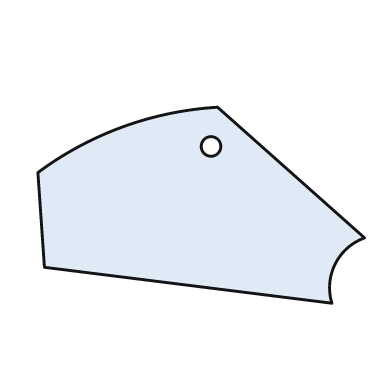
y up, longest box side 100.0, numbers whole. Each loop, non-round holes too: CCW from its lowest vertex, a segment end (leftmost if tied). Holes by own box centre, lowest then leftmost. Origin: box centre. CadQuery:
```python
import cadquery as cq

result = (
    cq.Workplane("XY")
    .moveTo(40.0, -30.0)
    .threePointArc((41.0, -18.0), (50.0, -10.0))
    .lineTo(5.0, 30.0)
    .threePointArc((-24.0, 24.0), (-50.0, 10.0))
    .lineTo(-48.0, -19.0)
    .close()
    .moveTo(3.0, 18.0)
    .circle(3.0)
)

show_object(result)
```